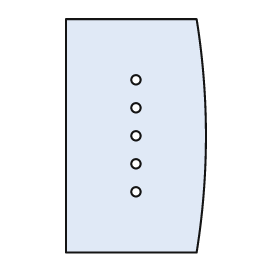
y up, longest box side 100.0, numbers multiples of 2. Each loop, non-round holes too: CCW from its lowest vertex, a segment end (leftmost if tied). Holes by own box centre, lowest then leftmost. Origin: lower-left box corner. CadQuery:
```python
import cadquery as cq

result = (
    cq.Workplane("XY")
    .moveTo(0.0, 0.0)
    .lineTo(56.0, 0.0)
    .threePointArc((60.0, 50.0), (56.0, 100.0))
    .lineTo(0.0, 100.0)
    .close()
    .moveTo(30.0, 26.0)
    .circle(2.0)
    .moveTo(30.0, 38.0)
    .circle(2.0)
    .moveTo(30.0, 50.0)
    .circle(2.0)
    .moveTo(30.0, 62.0)
    .circle(2.0)
    .moveTo(30.0, 74.0)
    .circle(2.0)
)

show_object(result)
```